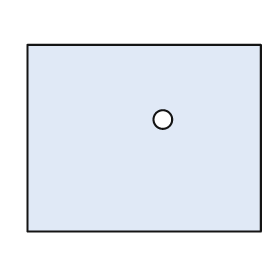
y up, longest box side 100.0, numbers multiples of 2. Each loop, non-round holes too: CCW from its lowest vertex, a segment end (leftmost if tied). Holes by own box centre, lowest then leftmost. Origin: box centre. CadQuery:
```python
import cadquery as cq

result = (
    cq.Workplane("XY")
    .moveTo(-50.0, -40.0)
    .lineTo(50.0, -40.0)
    .lineTo(50.0, 40.0)
    .lineTo(-50.0, 40.0)
    .close()
    .moveTo(8.0, 8.0)
    .circle(4.0)
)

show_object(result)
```